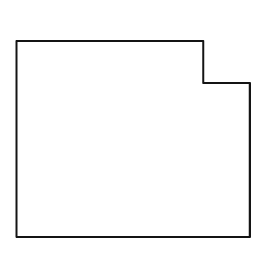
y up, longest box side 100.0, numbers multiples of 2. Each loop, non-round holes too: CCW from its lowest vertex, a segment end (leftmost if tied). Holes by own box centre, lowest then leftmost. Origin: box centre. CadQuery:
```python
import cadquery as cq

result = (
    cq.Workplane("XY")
    .moveTo(-50.0, -42.0)
    .lineTo(50.0, -42.0)
    .lineTo(50.0, 24.0)
    .lineTo(30.0, 24.0)
    .lineTo(30.0, 42.0)
    .lineTo(-50.0, 42.0)
    .close()
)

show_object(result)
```